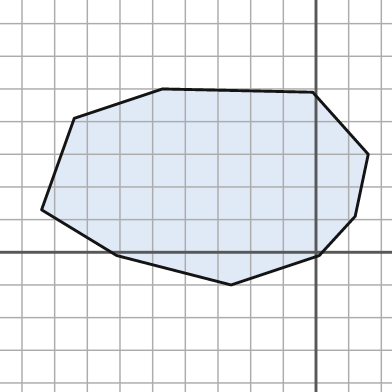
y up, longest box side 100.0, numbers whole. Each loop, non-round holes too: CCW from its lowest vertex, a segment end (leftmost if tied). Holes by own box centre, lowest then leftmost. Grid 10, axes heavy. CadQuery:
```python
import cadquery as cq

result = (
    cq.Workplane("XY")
    .moveTo(-26.0, -10.0)
    .lineTo(1.0, -1.0)
    .lineTo(12.0, 11.0)
    .lineTo(16.0, 30.0)
    .lineTo(-1.0, 49.0)
    .lineTo(-47.0, 50.0)
    .lineTo(-74.0, 41.0)
    .lineTo(-84.0, 13.0)
    .lineTo(-61.0, -1.0)
    .close()
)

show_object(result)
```